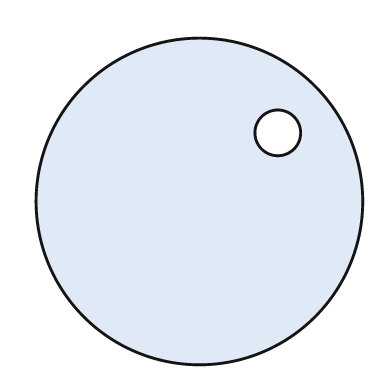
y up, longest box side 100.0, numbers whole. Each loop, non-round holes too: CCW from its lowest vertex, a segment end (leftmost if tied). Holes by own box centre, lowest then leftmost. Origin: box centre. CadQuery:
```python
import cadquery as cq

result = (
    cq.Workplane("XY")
    .moveTo(0.0, 0.0)
    .circle(50.0)
    .moveTo(24.0, 21.0)
    .circle(7.0)
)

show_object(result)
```